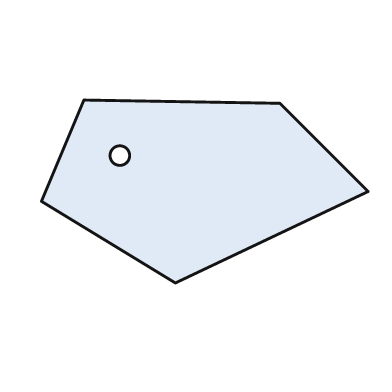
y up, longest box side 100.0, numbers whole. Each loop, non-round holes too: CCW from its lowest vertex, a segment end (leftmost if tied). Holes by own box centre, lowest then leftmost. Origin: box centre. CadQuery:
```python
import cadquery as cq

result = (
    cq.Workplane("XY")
    .moveTo(-9.0, -28.0)
    .lineTo(50.0, 0.0)
    .lineTo(23.0, 27.0)
    .lineTo(-37.0, 28.0)
    .lineTo(-50.0, -3.0)
    .close()
    .moveTo(-26.0, 11.0)
    .circle(3.0)
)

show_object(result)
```